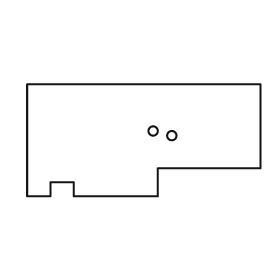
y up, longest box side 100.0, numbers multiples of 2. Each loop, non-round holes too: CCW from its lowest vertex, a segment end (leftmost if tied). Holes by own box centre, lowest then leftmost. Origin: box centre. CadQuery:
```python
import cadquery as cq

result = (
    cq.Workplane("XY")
    .moveTo(-50.0, -24.0)
    .lineTo(-40.0, -24.0)
    .lineTo(-40.0, -18.0)
    .lineTo(-30.0, -18.0)
    .lineTo(-30.0, -24.0)
    .lineTo(6.0, -24.0)
    .lineTo(6.0, -12.0)
    .lineTo(50.0, -12.0)
    .lineTo(50.0, 24.0)
    .lineTo(-50.0, 24.0)
    .close()
    .moveTo(12.0, 2.0)
    .circle(2.0)
    .moveTo(4.0, 4.0)
    .circle(2.0)
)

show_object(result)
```